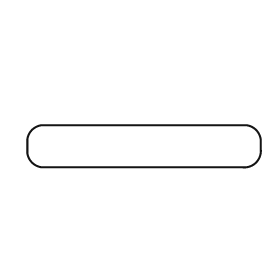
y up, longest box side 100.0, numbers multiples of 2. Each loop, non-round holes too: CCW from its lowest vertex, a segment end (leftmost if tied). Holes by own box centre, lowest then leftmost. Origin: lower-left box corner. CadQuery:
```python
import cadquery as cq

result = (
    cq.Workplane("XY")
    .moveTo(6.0, 0.0)
    .lineTo(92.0, 0.0)
    .threePointArc((98.0, 2.0), (100.0, 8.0))
    .lineTo(100.0, 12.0)
    .threePointArc((98.0, 16.0), (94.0, 18.0))
    .lineTo(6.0, 18.0)
    .threePointArc((2.0, 16.0), (0.0, 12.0))
    .lineTo(0.0, 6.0)
    .threePointArc((2.0, 2.0), (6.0, 0.0))
    .close()
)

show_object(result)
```